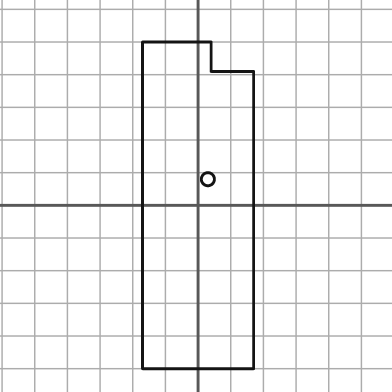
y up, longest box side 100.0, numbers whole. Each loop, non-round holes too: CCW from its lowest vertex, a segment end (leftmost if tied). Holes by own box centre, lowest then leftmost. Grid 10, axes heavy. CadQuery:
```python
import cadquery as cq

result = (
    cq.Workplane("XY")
    .moveTo(-17.0, -50.0)
    .lineTo(17.0, -50.0)
    .lineTo(17.0, 41.0)
    .lineTo(4.0, 41.0)
    .lineTo(4.0, 50.0)
    .lineTo(-17.0, 50.0)
    .close()
    .moveTo(3.0, 8.0)
    .circle(2.0)
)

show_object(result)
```